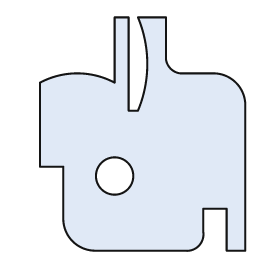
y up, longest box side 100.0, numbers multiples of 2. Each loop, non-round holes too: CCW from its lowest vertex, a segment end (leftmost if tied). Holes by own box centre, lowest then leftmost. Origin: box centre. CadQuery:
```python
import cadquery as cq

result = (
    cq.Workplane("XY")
    .moveTo(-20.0, -50.0)
    .lineTo(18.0, -50.0)
    .threePointArc((24.0, -48.0), (26.0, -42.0))
    .lineTo(26.0, -32.0)
    .lineTo(36.0, -32.0)
    .lineTo(36.0, -50.0)
    .lineTo(44.0, -50.0)
    .lineTo(44.0, 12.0)
    .threePointArc((40.0, 22.0), (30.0, 26.0))
    .lineTo(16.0, 26.0)
    .threePointArc((12.0, 28.0), (10.0, 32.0))
    .lineTo(10.0, 50.0)
    .lineTo(-2.0, 50.0)
    .threePointArc((2.0, 30.0), (-2.0, 10.0))
    .lineTo(-6.0, 10.0)
    .lineTo(-6.0, 50.0)
    .lineTo(-12.0, 50.0)
    .lineTo(-12.0, 22.0)
    .threePointArc((-28.0, 26.0), (-44.0, 22.0))
    .lineTo(-44.0, -14.0)
    .lineTo(-34.0, -14.0)
    .lineTo(-34.0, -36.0)
    .threePointArc((-30.0, -46.0), (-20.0, -50.0))
    .close()
    .moveTo(-12.0, -18.0)
    .circle(8.0)
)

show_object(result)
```